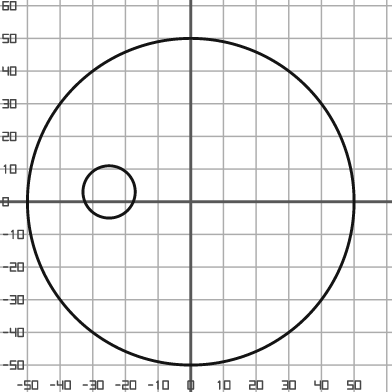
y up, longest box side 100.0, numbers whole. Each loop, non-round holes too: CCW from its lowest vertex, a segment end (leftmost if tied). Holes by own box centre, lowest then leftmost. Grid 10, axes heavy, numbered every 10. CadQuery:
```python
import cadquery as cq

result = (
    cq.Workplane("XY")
    .moveTo(0.0, 0.0)
    .circle(50.0)
    .moveTo(-25.0, 3.0)
    .circle(8.0)
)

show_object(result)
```